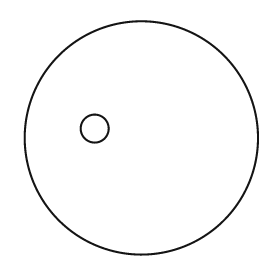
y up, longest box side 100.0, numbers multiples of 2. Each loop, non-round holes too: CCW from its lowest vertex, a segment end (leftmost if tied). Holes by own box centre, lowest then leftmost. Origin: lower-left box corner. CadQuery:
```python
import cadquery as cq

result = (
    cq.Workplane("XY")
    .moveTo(50.0, 50.0)
    .circle(50.0)
    .moveTo(30.0, 54.0)
    .circle(6.0)
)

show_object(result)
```